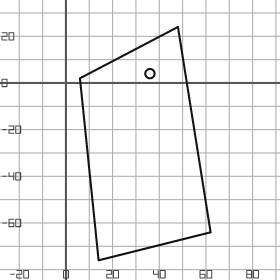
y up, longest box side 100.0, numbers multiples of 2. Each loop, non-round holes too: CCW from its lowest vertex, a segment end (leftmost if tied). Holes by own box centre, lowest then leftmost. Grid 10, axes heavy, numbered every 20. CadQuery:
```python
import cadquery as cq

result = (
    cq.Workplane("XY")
    .moveTo(14.0, -76.0)
    .lineTo(62.0, -64.0)
    .lineTo(48.0, 24.0)
    .lineTo(6.0, 2.0)
    .close()
    .moveTo(36.0, 4.0)
    .circle(2.0)
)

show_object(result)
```